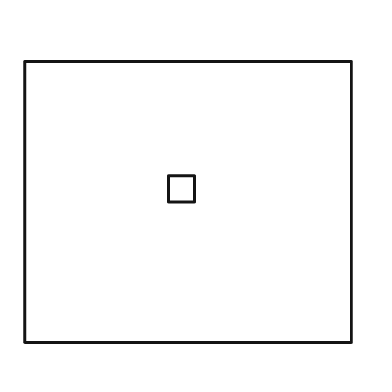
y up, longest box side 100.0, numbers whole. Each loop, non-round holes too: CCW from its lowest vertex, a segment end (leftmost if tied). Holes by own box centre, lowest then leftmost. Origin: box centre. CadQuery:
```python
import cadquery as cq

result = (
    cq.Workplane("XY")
    .moveTo(-50.0, -43.0)
    .lineTo(50.0, -43.0)
    .lineTo(50.0, 43.0)
    .lineTo(-50.0, 43.0)
    .close()
    .moveTo(-6.0, 0.0)
    .lineTo(2.0, 0.0)
    .lineTo(2.0, 8.0)
    .lineTo(-6.0, 8.0)
    .close()
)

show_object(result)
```